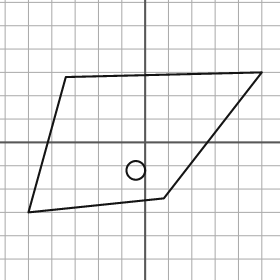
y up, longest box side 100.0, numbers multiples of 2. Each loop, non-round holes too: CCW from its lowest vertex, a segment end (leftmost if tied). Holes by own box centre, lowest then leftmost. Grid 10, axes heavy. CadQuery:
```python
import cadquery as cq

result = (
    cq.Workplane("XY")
    .moveTo(-50.0, -30.0)
    .lineTo(8.0, -24.0)
    .lineTo(50.0, 30.0)
    .lineTo(-34.0, 28.0)
    .close()
    .moveTo(-4.0, -12.0)
    .circle(4.0)
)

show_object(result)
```